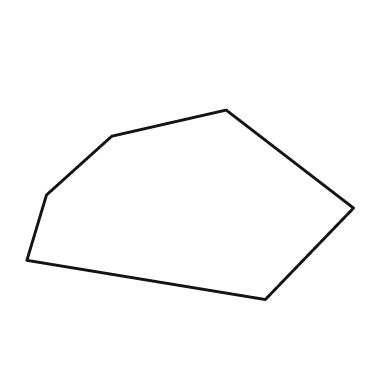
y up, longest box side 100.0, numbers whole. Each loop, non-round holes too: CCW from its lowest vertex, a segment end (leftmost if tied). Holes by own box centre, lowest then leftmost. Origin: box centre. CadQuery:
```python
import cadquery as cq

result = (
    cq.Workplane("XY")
    .moveTo(23.0, -29.0)
    .lineTo(50.0, -1.0)
    .lineTo(11.0, 29.0)
    .lineTo(-24.0, 21.0)
    .lineTo(-44.0, 3.0)
    .lineTo(-50.0, -17.0)
    .close()
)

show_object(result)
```